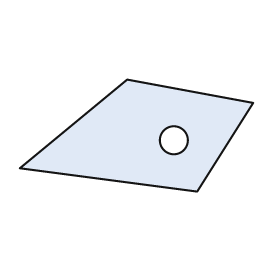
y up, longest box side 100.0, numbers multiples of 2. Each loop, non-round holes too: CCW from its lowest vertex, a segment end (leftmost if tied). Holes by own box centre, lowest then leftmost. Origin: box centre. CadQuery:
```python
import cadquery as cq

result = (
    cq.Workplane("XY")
    .moveTo(26.0, -24.0)
    .lineTo(50.0, 14.0)
    .lineTo(-4.0, 24.0)
    .lineTo(-50.0, -14.0)
    .close()
    .moveTo(16.0, -2.0)
    .circle(6.0)
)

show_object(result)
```